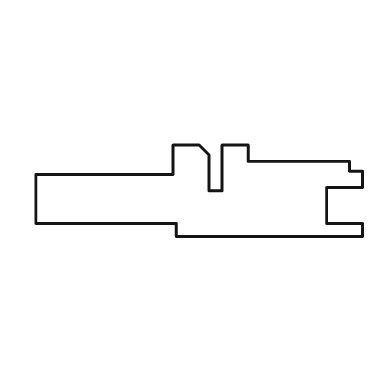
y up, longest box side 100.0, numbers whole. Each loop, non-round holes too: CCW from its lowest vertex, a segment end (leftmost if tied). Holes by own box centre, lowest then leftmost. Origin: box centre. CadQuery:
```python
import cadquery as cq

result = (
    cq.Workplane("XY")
    .moveTo(-7.0, -14.0)
    .lineTo(50.0, -14.0)
    .lineTo(50.0, -10.0)
    .lineTo(39.0, -10.0)
    .lineTo(39.0, 1.0)
    .lineTo(50.0, 1.0)
    .lineTo(50.0, 6.0)
    .lineTo(46.0, 6.0)
    .lineTo(46.0, 9.0)
    .lineTo(15.0, 9.0)
    .lineTo(15.0, 14.0)
    .lineTo(7.0, 14.0)
    .lineTo(7.0, 0.0)
    .lineTo(3.0, 0.0)
    .lineTo(3.0, 11.0)
    .lineTo(0.0, 14.0)
    .lineTo(-8.0, 14.0)
    .lineTo(-8.0, 5.0)
    .lineTo(-50.0, 5.0)
    .lineTo(-50.0, -10.0)
    .lineTo(-7.0, -10.0)
    .close()
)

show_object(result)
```